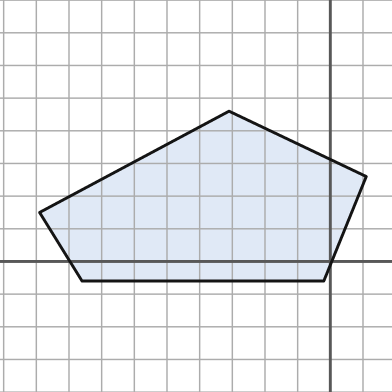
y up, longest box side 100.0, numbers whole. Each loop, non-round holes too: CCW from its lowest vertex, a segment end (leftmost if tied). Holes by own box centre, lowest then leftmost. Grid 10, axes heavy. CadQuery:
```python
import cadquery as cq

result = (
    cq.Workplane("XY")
    .moveTo(-76.0, -6.0)
    .lineTo(-2.0, -6.0)
    .lineTo(11.0, 26.0)
    .lineTo(-31.0, 46.0)
    .lineTo(-89.0, 15.0)
    .close()
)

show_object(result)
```